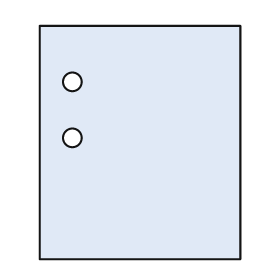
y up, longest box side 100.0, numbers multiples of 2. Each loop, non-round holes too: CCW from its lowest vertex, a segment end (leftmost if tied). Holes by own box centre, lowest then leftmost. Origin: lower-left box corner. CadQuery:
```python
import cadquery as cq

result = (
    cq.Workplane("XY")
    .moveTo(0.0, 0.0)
    .lineTo(86.0, 0.0)
    .lineTo(86.0, 100.0)
    .lineTo(0.0, 100.0)
    .close()
    .moveTo(14.0, 52.0)
    .circle(4.0)
    .moveTo(14.0, 76.0)
    .circle(4.0)
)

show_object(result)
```